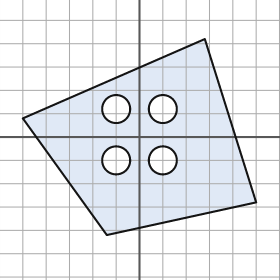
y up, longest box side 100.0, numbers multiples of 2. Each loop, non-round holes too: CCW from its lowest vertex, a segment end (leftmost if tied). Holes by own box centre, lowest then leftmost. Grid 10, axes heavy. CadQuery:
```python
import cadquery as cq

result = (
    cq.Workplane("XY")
    .moveTo(-14.0, -42.0)
    .lineTo(50.0, -28.0)
    .lineTo(28.0, 42.0)
    .lineTo(-50.0, 8.0)
    .close()
    .moveTo(-10.0, -10.0)
    .circle(6.0)
    .moveTo(10.0, -10.0)
    .circle(6.0)
    .moveTo(-10.0, 12.0)
    .circle(6.0)
    .moveTo(10.0, 12.0)
    .circle(6.0)
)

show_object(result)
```